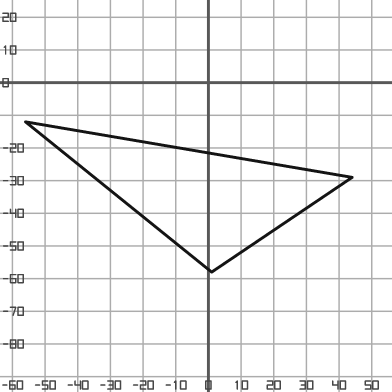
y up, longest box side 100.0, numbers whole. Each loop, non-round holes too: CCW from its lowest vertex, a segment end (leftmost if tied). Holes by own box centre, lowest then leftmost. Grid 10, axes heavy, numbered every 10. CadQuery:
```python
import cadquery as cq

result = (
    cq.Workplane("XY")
    .moveTo(1.0, -58.0)
    .lineTo(44.0, -29.0)
    .lineTo(-56.0, -12.0)
    .close()
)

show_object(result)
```